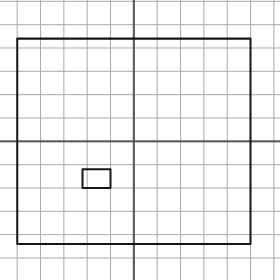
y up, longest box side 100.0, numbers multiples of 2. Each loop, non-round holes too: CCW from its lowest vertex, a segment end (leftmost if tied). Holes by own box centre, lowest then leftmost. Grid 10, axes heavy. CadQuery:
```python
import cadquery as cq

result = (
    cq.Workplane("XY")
    .moveTo(-50.0, -44.0)
    .lineTo(50.0, -44.0)
    .lineTo(50.0, 44.0)
    .lineTo(-50.0, 44.0)
    .close()
    .moveTo(-22.0, -20.0)
    .lineTo(-10.0, -20.0)
    .lineTo(-10.0, -12.0)
    .lineTo(-22.0, -12.0)
    .close()
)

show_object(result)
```